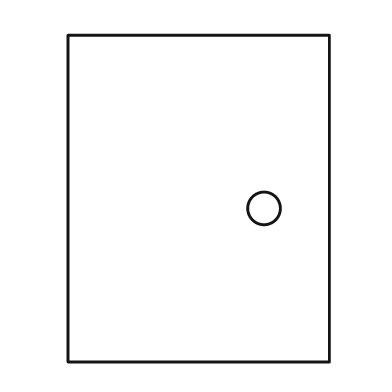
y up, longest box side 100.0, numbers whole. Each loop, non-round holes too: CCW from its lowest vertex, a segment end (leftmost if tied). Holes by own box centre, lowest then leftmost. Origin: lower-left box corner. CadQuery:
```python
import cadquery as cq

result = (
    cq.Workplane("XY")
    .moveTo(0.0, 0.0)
    .lineTo(80.0, 0.0)
    .lineTo(80.0, 100.0)
    .lineTo(0.0, 100.0)
    .close()
    .moveTo(60.0, 47.0)
    .circle(5.0)
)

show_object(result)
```